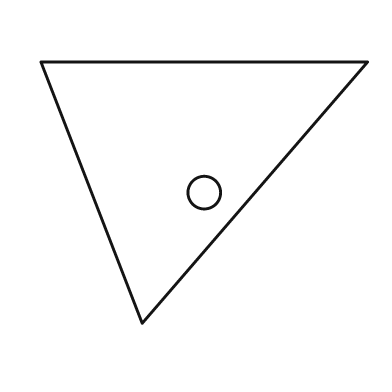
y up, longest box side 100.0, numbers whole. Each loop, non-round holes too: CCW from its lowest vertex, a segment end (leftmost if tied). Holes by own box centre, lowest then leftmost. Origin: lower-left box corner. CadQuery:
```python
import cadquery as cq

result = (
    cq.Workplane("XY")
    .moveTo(31.0, 0.0)
    .lineTo(100.0, 80.0)
    .lineTo(0.0, 80.0)
    .close()
    .moveTo(50.0, 40.0)
    .circle(5.0)
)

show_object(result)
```